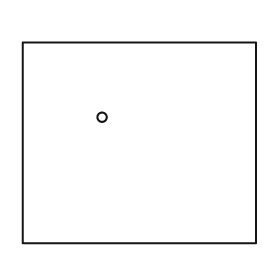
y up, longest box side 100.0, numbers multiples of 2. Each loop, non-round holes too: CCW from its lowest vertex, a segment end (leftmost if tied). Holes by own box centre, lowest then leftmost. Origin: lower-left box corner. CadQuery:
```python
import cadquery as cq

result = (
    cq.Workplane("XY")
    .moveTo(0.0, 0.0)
    .lineTo(100.0, 0.0)
    .lineTo(100.0, 86.0)
    .lineTo(0.0, 86.0)
    .close()
    .moveTo(34.0, 54.0)
    .circle(2.0)
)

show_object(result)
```